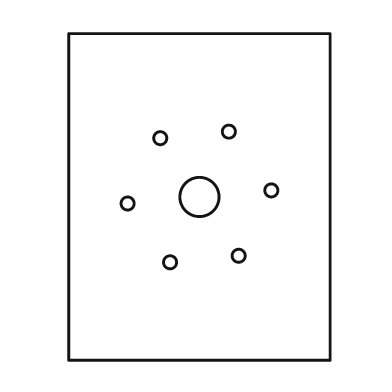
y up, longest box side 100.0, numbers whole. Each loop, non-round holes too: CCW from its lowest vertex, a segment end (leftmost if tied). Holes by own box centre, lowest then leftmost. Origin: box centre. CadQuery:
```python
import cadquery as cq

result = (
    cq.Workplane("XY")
    .moveTo(-40.0, -50.0)
    .lineTo(40.0, -50.0)
    .lineTo(40.0, 50.0)
    .lineTo(-40.0, 50.0)
    .close()
    .moveTo(-9.0, -20.0)
    .circle(2.0)
    .moveTo(12.0, -18.0)
    .circle(2.0)
    .moveTo(-22.0, -2.0)
    .circle(2.0)
    .moveTo(0.0, 0.0)
    .circle(6.0)
    .moveTo(22.0, 2.0)
    .circle(2.0)
    .moveTo(-12.0, 18.0)
    .circle(2.0)
    .moveTo(9.0, 20.0)
    .circle(2.0)
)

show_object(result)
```